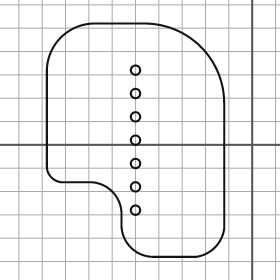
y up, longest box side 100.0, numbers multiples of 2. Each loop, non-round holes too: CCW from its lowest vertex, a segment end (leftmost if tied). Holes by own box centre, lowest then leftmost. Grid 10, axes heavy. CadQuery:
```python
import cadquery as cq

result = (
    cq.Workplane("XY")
    .moveTo(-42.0, -48.0)
    .lineTo(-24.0, -48.0)
    .threePointArc((-16.0, -44.0), (-12.0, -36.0))
    .lineTo(-12.0, 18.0)
    .threePointArc((-22.0, 42.0), (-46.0, 52.0))
    .lineTo(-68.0, 52.0)
    .threePointArc((-82.0, 46.0), (-88.0, 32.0))
    .lineTo(-88.0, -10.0)
    .threePointArc((-86.0, -14.0), (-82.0, -16.0))
    .lineTo(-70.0, -16.0)
    .threePointArc((-60.0, -20.0), (-56.0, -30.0))
    .lineTo(-56.0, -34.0)
    .threePointArc((-52.0, -44.0), (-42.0, -48.0))
    .close()
    .moveTo(-50.0, -28.0)
    .circle(2.0)
    .moveTo(-50.0, -18.0)
    .circle(2.0)
    .moveTo(-50.0, -8.0)
    .circle(2.0)
    .moveTo(-50.0, 2.0)
    .circle(2.0)
    .moveTo(-50.0, 12.0)
    .circle(2.0)
    .moveTo(-50.0, 22.0)
    .circle(2.0)
    .moveTo(-50.0, 32.0)
    .circle(2.0)
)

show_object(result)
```